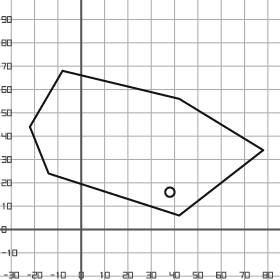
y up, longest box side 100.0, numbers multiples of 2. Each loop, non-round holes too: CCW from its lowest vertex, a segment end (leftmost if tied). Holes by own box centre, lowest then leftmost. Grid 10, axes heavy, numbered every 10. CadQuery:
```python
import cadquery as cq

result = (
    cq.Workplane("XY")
    .moveTo(42.0, 6.0)
    .lineTo(78.0, 34.0)
    .lineTo(42.0, 56.0)
    .lineTo(-8.0, 68.0)
    .lineTo(-22.0, 44.0)
    .lineTo(-14.0, 24.0)
    .close()
    .moveTo(38.0, 16.0)
    .circle(2.0)
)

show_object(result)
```